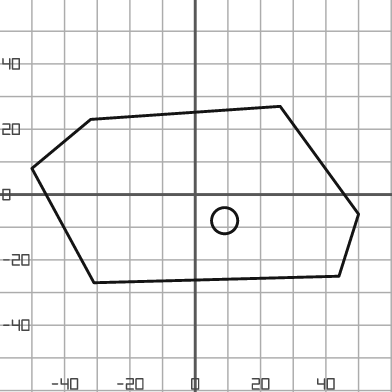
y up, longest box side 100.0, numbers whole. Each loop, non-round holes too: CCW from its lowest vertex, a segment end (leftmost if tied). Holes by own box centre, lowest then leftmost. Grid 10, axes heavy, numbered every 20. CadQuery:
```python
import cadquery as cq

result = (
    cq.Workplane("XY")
    .moveTo(-31.0, -27.0)
    .lineTo(44.0, -25.0)
    .lineTo(50.0, -6.0)
    .lineTo(26.0, 27.0)
    .lineTo(-32.0, 23.0)
    .lineTo(-50.0, 8.0)
    .close()
    .moveTo(9.0, -8.0)
    .circle(4.0)
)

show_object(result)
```